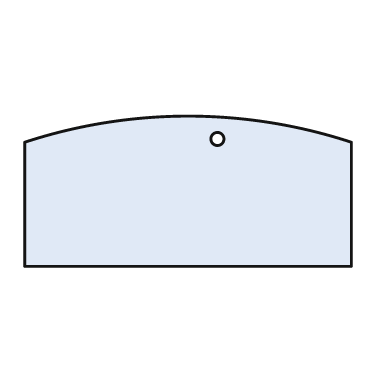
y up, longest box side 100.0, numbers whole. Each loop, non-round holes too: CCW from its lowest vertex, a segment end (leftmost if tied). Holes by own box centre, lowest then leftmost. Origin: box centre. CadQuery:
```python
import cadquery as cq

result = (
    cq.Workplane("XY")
    .moveTo(-50.0, -23.0)
    .lineTo(50.0, -23.0)
    .lineTo(50.0, 15.0)
    .threePointArc((0.0, 23.0), (-50.0, 15.0))
    .close()
    .moveTo(9.0, 16.0)
    .circle(2.0)
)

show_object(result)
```